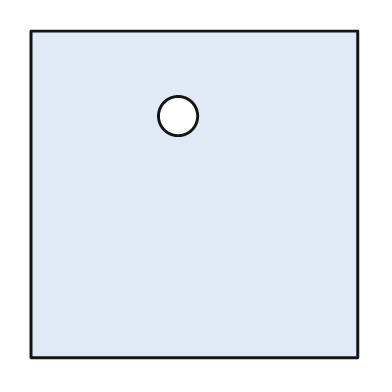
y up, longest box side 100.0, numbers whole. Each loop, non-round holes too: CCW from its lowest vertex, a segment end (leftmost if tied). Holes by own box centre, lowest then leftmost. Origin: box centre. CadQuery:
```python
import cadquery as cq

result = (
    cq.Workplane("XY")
    .moveTo(-50.0, -50.0)
    .lineTo(50.0, -50.0)
    .lineTo(50.0, 50.0)
    .lineTo(-50.0, 50.0)
    .close()
    .moveTo(-5.0, 24.0)
    .circle(6.0)
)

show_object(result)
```